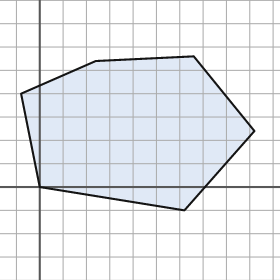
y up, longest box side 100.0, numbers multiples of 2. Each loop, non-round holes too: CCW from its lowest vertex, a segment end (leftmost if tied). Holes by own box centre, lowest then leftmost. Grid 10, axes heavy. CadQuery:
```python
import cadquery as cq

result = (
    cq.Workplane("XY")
    .moveTo(62.0, -10.0)
    .lineTo(92.0, 24.0)
    .lineTo(66.0, 56.0)
    .lineTo(24.0, 54.0)
    .lineTo(-8.0, 40.0)
    .lineTo(0.0, 0.0)
    .close()
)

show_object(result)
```